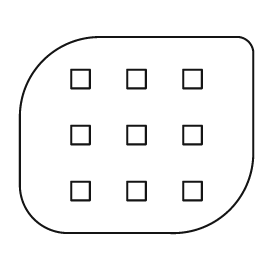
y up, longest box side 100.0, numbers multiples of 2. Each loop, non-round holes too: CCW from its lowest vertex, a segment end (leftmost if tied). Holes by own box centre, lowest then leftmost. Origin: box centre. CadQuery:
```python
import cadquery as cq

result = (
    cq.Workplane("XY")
    .moveTo(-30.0, -42.0)
    .lineTo(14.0, -42.0)
    .threePointArc((40.0, -32.0), (50.0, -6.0))
    .lineTo(50.0, 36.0)
    .threePointArc((48.0, 40.0), (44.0, 42.0))
    .lineTo(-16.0, 42.0)
    .threePointArc((-40.0, 32.0), (-50.0, 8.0))
    .lineTo(-50.0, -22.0)
    .threePointArc((-44.0, -36.0), (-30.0, -42.0))
    .close()
    .moveTo(-28.0, -28.0)
    .lineTo(-20.0, -28.0)
    .lineTo(-20.0, -20.0)
    .lineTo(-28.0, -20.0)
    .close()
    .moveTo(-4.0, -28.0)
    .lineTo(4.0, -28.0)
    .lineTo(4.0, -20.0)
    .lineTo(-4.0, -20.0)
    .close()
    .moveTo(20.0, -28.0)
    .lineTo(28.0, -28.0)
    .lineTo(28.0, -20.0)
    .lineTo(20.0, -20.0)
    .close()
    .moveTo(-28.0, -4.0)
    .lineTo(-20.0, -4.0)
    .lineTo(-20.0, 4.0)
    .lineTo(-28.0, 4.0)
    .close()
    .moveTo(-4.0, -4.0)
    .lineTo(4.0, -4.0)
    .lineTo(4.0, 4.0)
    .lineTo(-4.0, 4.0)
    .close()
    .moveTo(20.0, -4.0)
    .lineTo(28.0, -4.0)
    .lineTo(28.0, 4.0)
    .lineTo(20.0, 4.0)
    .close()
    .moveTo(-28.0, 20.0)
    .lineTo(-20.0, 20.0)
    .lineTo(-20.0, 28.0)
    .lineTo(-28.0, 28.0)
    .close()
    .moveTo(-4.0, 20.0)
    .lineTo(4.0, 20.0)
    .lineTo(4.0, 28.0)
    .lineTo(-4.0, 28.0)
    .close()
    .moveTo(20.0, 20.0)
    .lineTo(28.0, 20.0)
    .lineTo(28.0, 28.0)
    .lineTo(20.0, 28.0)
    .close()
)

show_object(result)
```